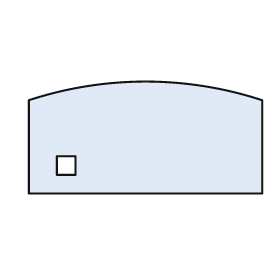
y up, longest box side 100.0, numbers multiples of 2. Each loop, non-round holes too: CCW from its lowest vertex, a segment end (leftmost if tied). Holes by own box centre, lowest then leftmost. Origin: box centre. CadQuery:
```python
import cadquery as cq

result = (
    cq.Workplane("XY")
    .moveTo(-50.0, -24.0)
    .lineTo(50.0, -24.0)
    .lineTo(50.0, 16.0)
    .threePointArc((0.0, 24.0), (-50.0, 16.0))
    .close()
    .moveTo(-38.0, -16.0)
    .lineTo(-30.0, -16.0)
    .lineTo(-30.0, -8.0)
    .lineTo(-38.0, -8.0)
    .close()
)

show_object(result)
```